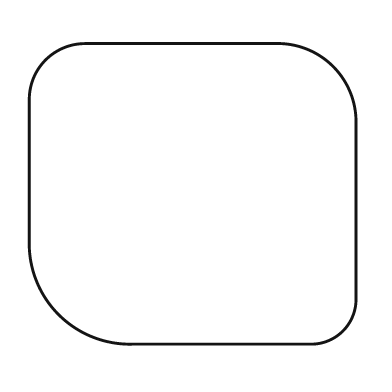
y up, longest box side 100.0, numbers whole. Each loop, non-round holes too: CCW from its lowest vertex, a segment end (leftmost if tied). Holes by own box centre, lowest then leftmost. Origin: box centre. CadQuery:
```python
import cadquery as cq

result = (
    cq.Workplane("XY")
    .moveTo(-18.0, -46.0)
    .lineTo(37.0, -46.0)
    .threePointArc((46.0, -42.0), (50.0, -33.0))
    .lineTo(50.0, 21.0)
    .threePointArc((43.0, 39.0), (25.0, 46.0))
    .lineTo(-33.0, 46.0)
    .threePointArc((-45.0, 41.0), (-50.0, 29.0))
    .lineTo(-50.0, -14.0)
    .threePointArc((-41.0, -37.0), (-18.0, -46.0))
    .close()
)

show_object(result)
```